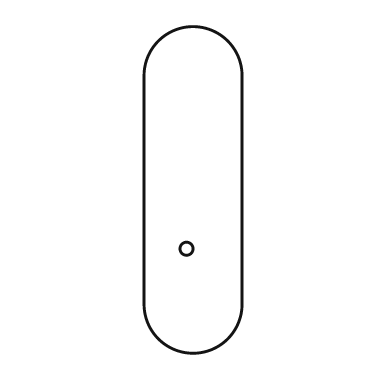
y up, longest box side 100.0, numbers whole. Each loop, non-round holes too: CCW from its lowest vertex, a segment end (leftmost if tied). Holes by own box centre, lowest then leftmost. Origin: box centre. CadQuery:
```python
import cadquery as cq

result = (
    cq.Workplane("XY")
    .moveTo(-15.0, -35.0)
    .threePointArc((0.0, -50.0), (15.0, -35.0))
    .lineTo(15.0, 35.0)
    .threePointArc((0.0, 50.0), (-15.0, 35.0))
    .close()
    .moveTo(-2.0, -18.0)
    .circle(2.0)
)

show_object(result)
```